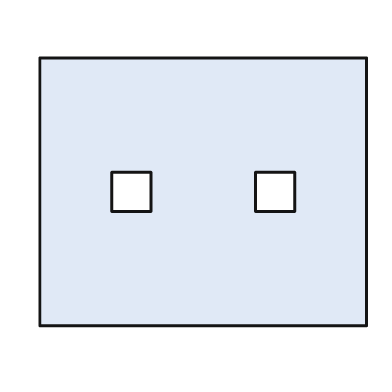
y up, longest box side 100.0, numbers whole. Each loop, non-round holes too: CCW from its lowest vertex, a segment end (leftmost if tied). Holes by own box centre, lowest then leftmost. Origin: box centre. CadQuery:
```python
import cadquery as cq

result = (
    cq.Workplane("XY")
    .moveTo(-50.0, -41.0)
    .lineTo(50.0, -41.0)
    .lineTo(50.0, 41.0)
    .lineTo(-50.0, 41.0)
    .close()
    .moveTo(-28.0, -6.0)
    .lineTo(-16.0, -6.0)
    .lineTo(-16.0, 6.0)
    .lineTo(-28.0, 6.0)
    .close()
    .moveTo(16.0, -6.0)
    .lineTo(28.0, -6.0)
    .lineTo(28.0, 6.0)
    .lineTo(16.0, 6.0)
    .close()
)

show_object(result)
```